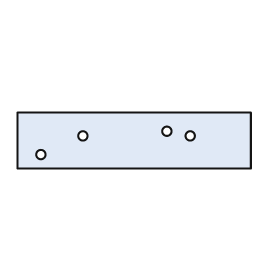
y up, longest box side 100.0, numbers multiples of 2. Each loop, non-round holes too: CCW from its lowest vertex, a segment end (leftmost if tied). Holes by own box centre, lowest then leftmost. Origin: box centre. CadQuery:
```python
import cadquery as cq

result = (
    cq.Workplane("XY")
    .moveTo(-50.0, -12.0)
    .lineTo(50.0, -12.0)
    .lineTo(50.0, 12.0)
    .lineTo(-50.0, 12.0)
    .close()
    .moveTo(-40.0, -6.0)
    .circle(2.0)
    .moveTo(-22.0, 2.0)
    .circle(2.0)
    .moveTo(24.0, 2.0)
    .circle(2.0)
    .moveTo(14.0, 4.0)
    .circle(2.0)
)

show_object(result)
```